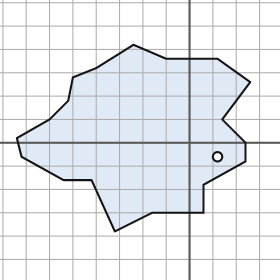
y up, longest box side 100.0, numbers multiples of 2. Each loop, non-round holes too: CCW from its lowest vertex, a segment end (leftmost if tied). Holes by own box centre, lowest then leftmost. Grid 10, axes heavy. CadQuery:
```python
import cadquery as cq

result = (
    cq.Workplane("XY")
    .moveTo(-32.0, -38.0)
    .lineTo(-16.0, -30.0)
    .lineTo(6.0, -30.0)
    .lineTo(6.0, -18.0)
    .lineTo(24.0, -8.0)
    .lineTo(24.0, 0.0)
    .lineTo(14.0, 10.0)
    .lineTo(26.0, 26.0)
    .lineTo(12.0, 36.0)
    .lineTo(-10.0, 36.0)
    .lineTo(-24.0, 42.0)
    .lineTo(-40.0, 32.0)
    .lineTo(-50.0, 28.0)
    .lineTo(-52.0, 18.0)
    .lineTo(-60.0, 10.0)
    .lineTo(-74.0, 2.0)
    .lineTo(-72.0, -6.0)
    .lineTo(-54.0, -16.0)
    .lineTo(-42.0, -16.0)
    .close()
    .moveTo(12.0, -6.0)
    .circle(2.0)
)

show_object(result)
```